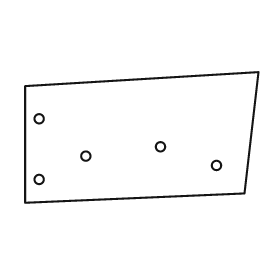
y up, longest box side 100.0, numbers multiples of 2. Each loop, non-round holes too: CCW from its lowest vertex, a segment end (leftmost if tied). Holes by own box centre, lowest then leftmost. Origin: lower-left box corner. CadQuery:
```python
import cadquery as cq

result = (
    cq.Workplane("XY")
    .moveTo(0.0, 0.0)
    .lineTo(94.0, 4.0)
    .lineTo(100.0, 56.0)
    .lineTo(0.0, 50.0)
    .close()
    .moveTo(6.0, 10.0)
    .circle(2.0)
    .moveTo(82.0, 16.0)
    .circle(2.0)
    .moveTo(26.0, 20.0)
    .circle(2.0)
    .moveTo(58.0, 24.0)
    .circle(2.0)
    .moveTo(6.0, 36.0)
    .circle(2.0)
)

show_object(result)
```